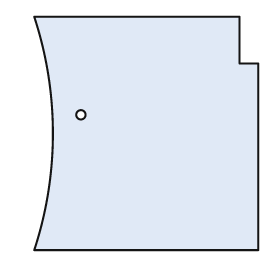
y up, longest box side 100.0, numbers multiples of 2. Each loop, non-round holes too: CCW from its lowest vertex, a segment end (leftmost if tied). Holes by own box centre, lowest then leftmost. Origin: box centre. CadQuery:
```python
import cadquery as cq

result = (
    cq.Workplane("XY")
    .moveTo(-48.0, -50.0)
    .lineTo(48.0, -50.0)
    .lineTo(48.0, 30.0)
    .lineTo(40.0, 30.0)
    .lineTo(40.0, 50.0)
    .lineTo(-48.0, 50.0)
    .threePointArc((-40.0, 0.0), (-48.0, -50.0))
    .close()
    .moveTo(-28.0, 8.0)
    .circle(2.0)
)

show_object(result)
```